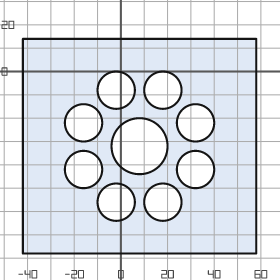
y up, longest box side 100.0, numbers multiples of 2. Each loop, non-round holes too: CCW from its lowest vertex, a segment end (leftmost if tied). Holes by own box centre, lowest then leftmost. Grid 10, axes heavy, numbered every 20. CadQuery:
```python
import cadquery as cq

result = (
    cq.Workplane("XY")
    .moveTo(-42.0, -78.0)
    .lineTo(58.0, -78.0)
    .lineTo(58.0, 14.0)
    .lineTo(-42.0, 14.0)
    .close()
    .moveTo(-2.0, -56.0)
    .circle(8.0)
    .moveTo(18.0, -56.0)
    .circle(8.0)
    .moveTo(-16.0, -42.0)
    .circle(8.0)
    .moveTo(32.0, -42.0)
    .circle(8.0)
    .moveTo(8.0, -32.0)
    .circle(12.0)
    .moveTo(-16.0, -22.0)
    .circle(8.0)
    .moveTo(32.0, -22.0)
    .circle(8.0)
    .moveTo(-2.0, -8.0)
    .circle(8.0)
    .moveTo(18.0, -8.0)
    .circle(8.0)
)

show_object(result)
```